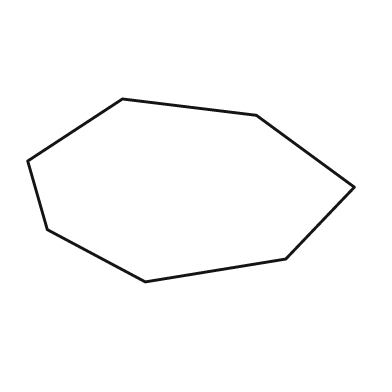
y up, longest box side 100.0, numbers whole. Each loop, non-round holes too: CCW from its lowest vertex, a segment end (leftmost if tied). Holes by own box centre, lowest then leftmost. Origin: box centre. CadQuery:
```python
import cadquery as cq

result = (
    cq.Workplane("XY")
    .moveTo(-14.0, -28.0)
    .lineTo(29.0, -21.0)
    .lineTo(50.0, 1.0)
    .lineTo(20.0, 23.0)
    .lineTo(-21.0, 28.0)
    .lineTo(-50.0, 9.0)
    .lineTo(-44.0, -12.0)
    .close()
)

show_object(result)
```